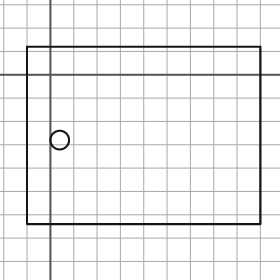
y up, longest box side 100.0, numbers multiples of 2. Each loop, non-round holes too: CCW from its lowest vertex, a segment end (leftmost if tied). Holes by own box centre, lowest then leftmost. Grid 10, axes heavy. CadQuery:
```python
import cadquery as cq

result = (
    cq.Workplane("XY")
    .moveTo(-10.0, -64.0)
    .lineTo(90.0, -64.0)
    .lineTo(90.0, 12.0)
    .lineTo(-10.0, 12.0)
    .close()
    .moveTo(4.0, -28.0)
    .circle(4.0)
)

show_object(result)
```